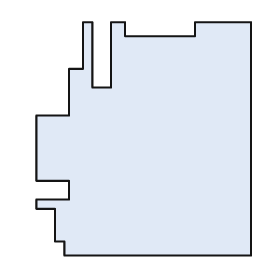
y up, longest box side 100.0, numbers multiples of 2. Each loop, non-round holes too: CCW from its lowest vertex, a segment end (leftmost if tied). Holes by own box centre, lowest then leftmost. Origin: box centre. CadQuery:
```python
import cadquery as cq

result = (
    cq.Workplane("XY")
    .moveTo(-34.0, -50.0)
    .lineTo(46.0, -50.0)
    .lineTo(46.0, 50.0)
    .lineTo(22.0, 50.0)
    .lineTo(22.0, 44.0)
    .lineTo(-8.0, 44.0)
    .lineTo(-8.0, 50.0)
    .lineTo(-14.0, 50.0)
    .lineTo(-14.0, 22.0)
    .lineTo(-22.0, 22.0)
    .lineTo(-22.0, 50.0)
    .lineTo(-26.0, 50.0)
    .lineTo(-26.0, 30.0)
    .lineTo(-32.0, 30.0)
    .lineTo(-32.0, 10.0)
    .lineTo(-46.0, 10.0)
    .lineTo(-46.0, -18.0)
    .lineTo(-32.0, -18.0)
    .lineTo(-32.0, -26.0)
    .lineTo(-46.0, -26.0)
    .lineTo(-46.0, -30.0)
    .lineTo(-38.0, -30.0)
    .lineTo(-38.0, -44.0)
    .lineTo(-34.0, -44.0)
    .close()
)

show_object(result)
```